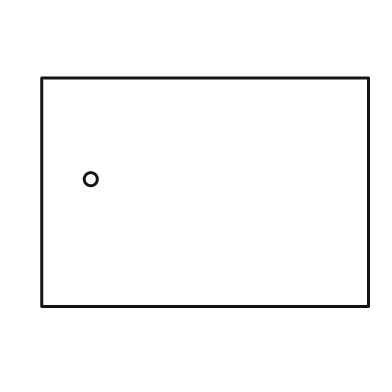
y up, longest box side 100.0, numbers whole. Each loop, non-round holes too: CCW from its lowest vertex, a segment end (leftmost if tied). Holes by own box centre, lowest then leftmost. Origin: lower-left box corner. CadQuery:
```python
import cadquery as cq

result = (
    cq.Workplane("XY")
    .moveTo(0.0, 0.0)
    .lineTo(100.0, 0.0)
    .lineTo(100.0, 70.0)
    .lineTo(0.0, 70.0)
    .close()
    .moveTo(15.0, 39.0)
    .circle(2.0)
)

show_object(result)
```